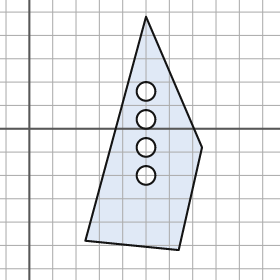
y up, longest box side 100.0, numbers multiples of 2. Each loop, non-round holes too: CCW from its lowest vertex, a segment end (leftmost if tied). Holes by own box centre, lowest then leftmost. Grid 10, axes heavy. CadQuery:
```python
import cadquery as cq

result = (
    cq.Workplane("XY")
    .moveTo(64.0, -52.0)
    .lineTo(74.0, -8.0)
    .lineTo(50.0, 48.0)
    .lineTo(24.0, -48.0)
    .close()
    .moveTo(50.0, -20.0)
    .circle(4.0)
    .moveTo(50.0, -8.0)
    .circle(4.0)
    .moveTo(50.0, 4.0)
    .circle(4.0)
    .moveTo(50.0, 16.0)
    .circle(4.0)
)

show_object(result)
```